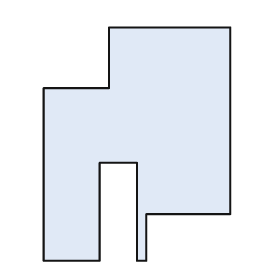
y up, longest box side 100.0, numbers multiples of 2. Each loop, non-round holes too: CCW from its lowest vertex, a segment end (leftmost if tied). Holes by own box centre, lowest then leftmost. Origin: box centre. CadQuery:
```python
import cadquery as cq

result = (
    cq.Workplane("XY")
    .moveTo(-40.0, -50.0)
    .lineTo(-16.0, -50.0)
    .lineTo(-16.0, -8.0)
    .lineTo(0.0, -8.0)
    .lineTo(0.0, -50.0)
    .lineTo(4.0, -50.0)
    .lineTo(4.0, -30.0)
    .lineTo(40.0, -30.0)
    .lineTo(40.0, 50.0)
    .lineTo(-12.0, 50.0)
    .lineTo(-12.0, 24.0)
    .lineTo(-40.0, 24.0)
    .close()
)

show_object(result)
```